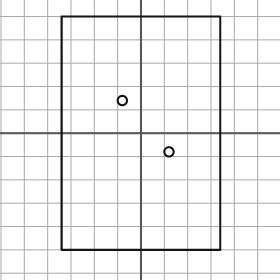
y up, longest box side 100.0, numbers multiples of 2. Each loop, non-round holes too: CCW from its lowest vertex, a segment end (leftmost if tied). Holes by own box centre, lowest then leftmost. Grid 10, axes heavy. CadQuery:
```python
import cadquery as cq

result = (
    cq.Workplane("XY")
    .moveTo(-34.0, -50.0)
    .lineTo(34.0, -50.0)
    .lineTo(34.0, 50.0)
    .lineTo(-34.0, 50.0)
    .close()
    .moveTo(12.0, -8.0)
    .circle(2.0)
    .moveTo(-8.0, 14.0)
    .circle(2.0)
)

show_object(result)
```